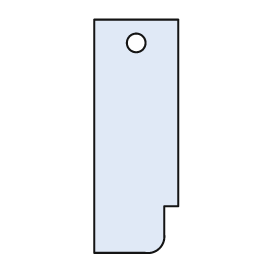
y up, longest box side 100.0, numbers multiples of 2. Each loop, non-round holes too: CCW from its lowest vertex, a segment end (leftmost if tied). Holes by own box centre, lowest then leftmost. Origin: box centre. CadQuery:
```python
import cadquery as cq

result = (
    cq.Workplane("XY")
    .moveTo(-18.0, -50.0)
    .lineTo(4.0, -50.0)
    .threePointArc((10.0, -48.0), (12.0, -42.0))
    .lineTo(12.0, -30.0)
    .lineTo(18.0, -30.0)
    .lineTo(18.0, 50.0)
    .lineTo(-18.0, 50.0)
    .close()
    .moveTo(0.0, 40.0)
    .circle(4.0)
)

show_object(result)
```